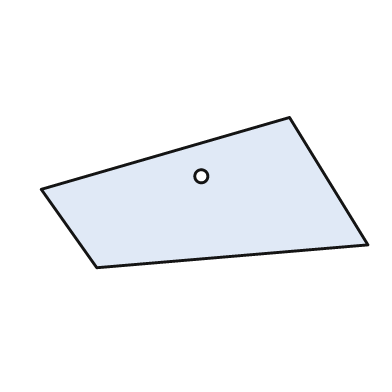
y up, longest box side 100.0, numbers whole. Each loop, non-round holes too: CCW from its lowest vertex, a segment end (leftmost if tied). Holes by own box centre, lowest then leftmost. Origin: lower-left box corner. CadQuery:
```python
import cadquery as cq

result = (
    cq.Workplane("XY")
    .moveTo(17.0, 0.0)
    .lineTo(100.0, 7.0)
    .lineTo(76.0, 46.0)
    .lineTo(0.0, 24.0)
    .close()
    .moveTo(49.0, 28.0)
    .circle(2.0)
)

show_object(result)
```